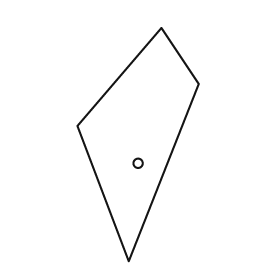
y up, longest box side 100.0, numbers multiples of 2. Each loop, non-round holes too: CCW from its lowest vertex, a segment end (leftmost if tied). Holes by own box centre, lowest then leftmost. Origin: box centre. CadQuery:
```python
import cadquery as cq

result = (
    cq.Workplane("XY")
    .moveTo(-4.0, -50.0)
    .lineTo(26.0, 26.0)
    .lineTo(10.0, 50.0)
    .lineTo(-26.0, 8.0)
    .close()
    .moveTo(0.0, -8.0)
    .circle(2.0)
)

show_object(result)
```